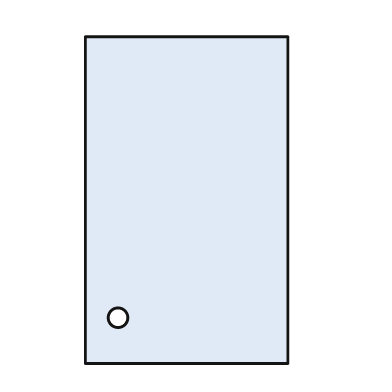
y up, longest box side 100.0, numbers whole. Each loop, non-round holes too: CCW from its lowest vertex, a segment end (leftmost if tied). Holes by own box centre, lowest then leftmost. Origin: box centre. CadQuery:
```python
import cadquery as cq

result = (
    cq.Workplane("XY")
    .moveTo(-31.0, -50.0)
    .lineTo(31.0, -50.0)
    .lineTo(31.0, 50.0)
    .lineTo(-31.0, 50.0)
    .close()
    .moveTo(-21.0, -36.0)
    .circle(3.0)
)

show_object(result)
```